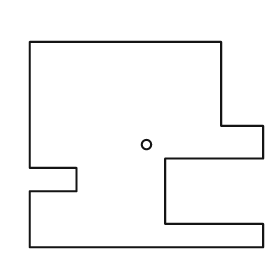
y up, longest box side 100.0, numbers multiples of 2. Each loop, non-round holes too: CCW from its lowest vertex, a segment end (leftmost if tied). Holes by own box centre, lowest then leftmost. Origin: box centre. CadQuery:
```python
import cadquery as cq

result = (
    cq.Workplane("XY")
    .moveTo(-50.0, -44.0)
    .lineTo(50.0, -44.0)
    .lineTo(50.0, -34.0)
    .lineTo(8.0, -34.0)
    .lineTo(8.0, -6.0)
    .lineTo(50.0, -6.0)
    .lineTo(50.0, 8.0)
    .lineTo(32.0, 8.0)
    .lineTo(32.0, 44.0)
    .lineTo(-50.0, 44.0)
    .lineTo(-50.0, -10.0)
    .lineTo(-30.0, -10.0)
    .lineTo(-30.0, -20.0)
    .lineTo(-50.0, -20.0)
    .close()
    .moveTo(0.0, 0.0)
    .circle(2.0)
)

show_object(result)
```